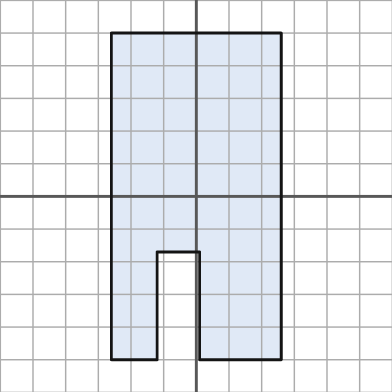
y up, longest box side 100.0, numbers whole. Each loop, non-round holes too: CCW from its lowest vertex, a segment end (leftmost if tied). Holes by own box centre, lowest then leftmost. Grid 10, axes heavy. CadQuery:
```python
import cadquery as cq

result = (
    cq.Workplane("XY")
    .moveTo(-26.0, -50.0)
    .lineTo(-12.0, -50.0)
    .lineTo(-12.0, -17.0)
    .lineTo(1.0, -17.0)
    .lineTo(1.0, -50.0)
    .lineTo(26.0, -50.0)
    .lineTo(26.0, 50.0)
    .lineTo(-26.0, 50.0)
    .close()
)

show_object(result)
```